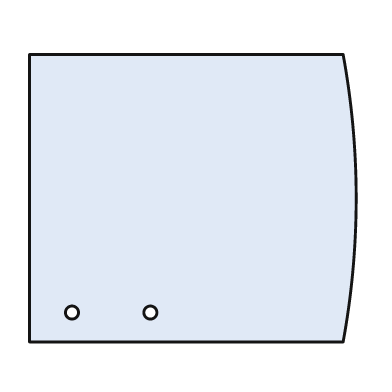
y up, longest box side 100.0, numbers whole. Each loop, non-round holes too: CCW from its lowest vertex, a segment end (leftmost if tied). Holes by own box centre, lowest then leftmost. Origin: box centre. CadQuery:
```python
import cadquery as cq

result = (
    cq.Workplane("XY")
    .moveTo(-50.0, -44.0)
    .lineTo(46.0, -44.0)
    .threePointArc((50.0, 0.0), (46.0, 44.0))
    .lineTo(-50.0, 44.0)
    .close()
    .moveTo(-37.0, -35.0)
    .circle(2.0)
    .moveTo(-13.0, -35.0)
    .circle(2.0)
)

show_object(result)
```